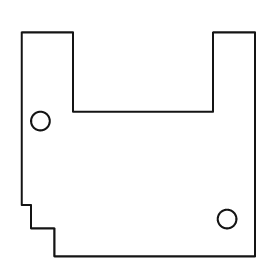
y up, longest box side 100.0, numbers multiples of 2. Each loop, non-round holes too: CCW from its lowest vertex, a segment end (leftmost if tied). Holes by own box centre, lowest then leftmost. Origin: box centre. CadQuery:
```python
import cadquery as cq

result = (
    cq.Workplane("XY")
    .moveTo(-36.0, -48.0)
    .lineTo(50.0, -48.0)
    .lineTo(50.0, 48.0)
    .lineTo(32.0, 48.0)
    .lineTo(32.0, 14.0)
    .lineTo(-28.0, 14.0)
    .lineTo(-28.0, 48.0)
    .lineTo(-50.0, 48.0)
    .lineTo(-50.0, -26.0)
    .lineTo(-46.0, -26.0)
    .lineTo(-46.0, -36.0)
    .lineTo(-36.0, -36.0)
    .close()
    .moveTo(38.0, -32.0)
    .circle(4.0)
    .moveTo(-42.0, 10.0)
    .circle(4.0)
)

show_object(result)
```